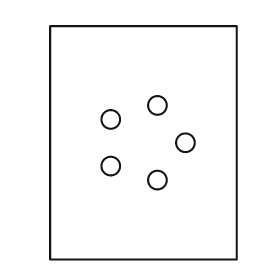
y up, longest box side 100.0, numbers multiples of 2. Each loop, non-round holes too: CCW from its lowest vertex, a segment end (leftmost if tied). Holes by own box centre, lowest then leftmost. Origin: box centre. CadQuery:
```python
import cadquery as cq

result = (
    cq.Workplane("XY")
    .moveTo(-40.0, -50.0)
    .lineTo(40.0, -50.0)
    .lineTo(40.0, 50.0)
    .lineTo(-40.0, 50.0)
    .close()
    .moveTo(6.0, -16.0)
    .circle(4.0)
    .moveTo(-14.0, -10.0)
    .circle(4.0)
    .moveTo(18.0, 0.0)
    .circle(4.0)
    .moveTo(-14.0, 10.0)
    .circle(4.0)
    .moveTo(6.0, 16.0)
    .circle(4.0)
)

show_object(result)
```